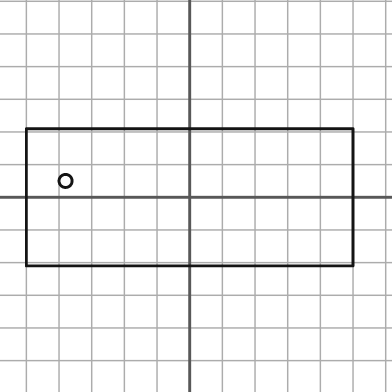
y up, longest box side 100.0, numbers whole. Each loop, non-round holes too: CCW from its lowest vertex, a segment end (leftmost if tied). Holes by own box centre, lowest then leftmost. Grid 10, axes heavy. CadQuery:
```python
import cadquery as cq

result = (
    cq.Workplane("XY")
    .moveTo(-50.0, -21.0)
    .lineTo(50.0, -21.0)
    .lineTo(50.0, 21.0)
    .lineTo(-50.0, 21.0)
    .close()
    .moveTo(-38.0, 5.0)
    .circle(2.0)
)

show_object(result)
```